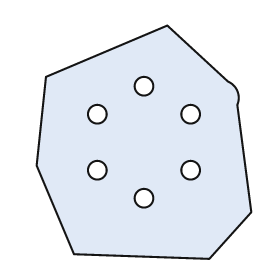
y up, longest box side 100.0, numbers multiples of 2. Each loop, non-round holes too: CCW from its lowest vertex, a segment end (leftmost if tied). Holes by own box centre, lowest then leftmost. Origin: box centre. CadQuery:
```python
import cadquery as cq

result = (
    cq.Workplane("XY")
    .moveTo(28.0, -50.0)
    .lineTo(46.0, -30.0)
    .lineTo(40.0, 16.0)
    .threePointArc((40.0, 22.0), (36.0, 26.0))
    .lineTo(10.0, 50.0)
    .lineTo(-42.0, 28.0)
    .lineTo(-46.0, -10.0)
    .lineTo(-30.0, -48.0)
    .close()
    .moveTo(0.0, -24.0)
    .circle(4.0)
    .moveTo(-20.0, -12.0)
    .circle(4.0)
    .moveTo(20.0, -12.0)
    .circle(4.0)
    .moveTo(-20.0, 12.0)
    .circle(4.0)
    .moveTo(20.0, 12.0)
    .circle(4.0)
    .moveTo(0.0, 24.0)
    .circle(4.0)
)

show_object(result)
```